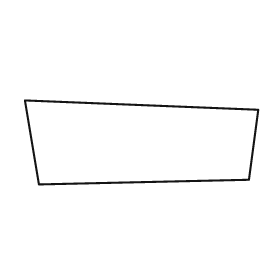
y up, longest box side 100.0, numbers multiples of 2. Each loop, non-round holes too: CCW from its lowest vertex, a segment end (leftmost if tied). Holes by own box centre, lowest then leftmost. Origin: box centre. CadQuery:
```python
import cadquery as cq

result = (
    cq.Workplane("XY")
    .moveTo(-44.0, -18.0)
    .lineTo(46.0, -16.0)
    .lineTo(50.0, 14.0)
    .lineTo(-50.0, 18.0)
    .close()
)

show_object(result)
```